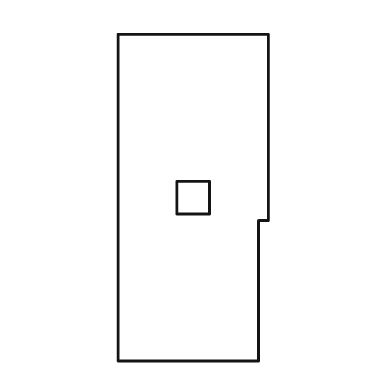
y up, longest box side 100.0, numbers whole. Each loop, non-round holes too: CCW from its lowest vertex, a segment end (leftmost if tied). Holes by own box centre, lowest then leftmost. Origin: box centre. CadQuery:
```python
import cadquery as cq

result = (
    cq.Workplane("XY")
    .moveTo(-23.0, -50.0)
    .lineTo(20.0, -50.0)
    .lineTo(20.0, -7.0)
    .lineTo(23.0, -7.0)
    .lineTo(23.0, 50.0)
    .lineTo(-23.0, 50.0)
    .close()
    .moveTo(-5.0, -5.0)
    .lineTo(5.0, -5.0)
    .lineTo(5.0, 5.0)
    .lineTo(-5.0, 5.0)
    .close()
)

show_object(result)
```